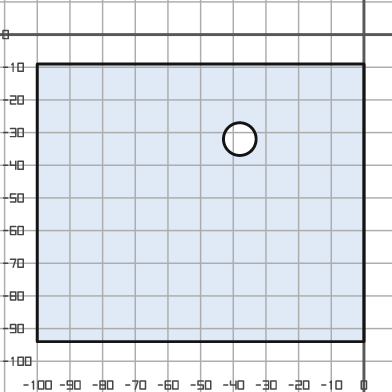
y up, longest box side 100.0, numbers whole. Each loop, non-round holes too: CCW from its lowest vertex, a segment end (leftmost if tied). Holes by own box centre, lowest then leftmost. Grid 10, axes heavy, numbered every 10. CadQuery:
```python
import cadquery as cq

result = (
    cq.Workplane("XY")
    .moveTo(-100.0, -94.0)
    .lineTo(0.0, -94.0)
    .lineTo(0.0, -9.0)
    .lineTo(-100.0, -9.0)
    .close()
    .moveTo(-38.0, -32.0)
    .circle(5.0)
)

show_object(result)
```